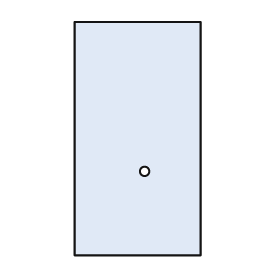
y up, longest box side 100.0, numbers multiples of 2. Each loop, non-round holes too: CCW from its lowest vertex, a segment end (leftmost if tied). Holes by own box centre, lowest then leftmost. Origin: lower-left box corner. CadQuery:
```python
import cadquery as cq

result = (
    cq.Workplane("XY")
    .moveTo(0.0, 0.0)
    .lineTo(54.0, 0.0)
    .lineTo(54.0, 100.0)
    .lineTo(0.0, 100.0)
    .close()
    .moveTo(30.0, 36.0)
    .circle(2.0)
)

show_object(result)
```